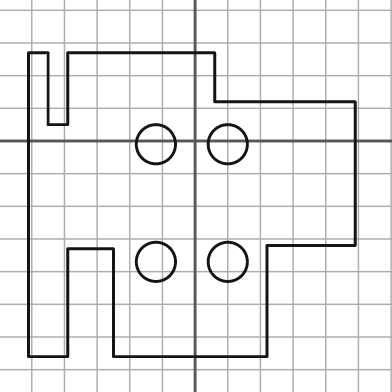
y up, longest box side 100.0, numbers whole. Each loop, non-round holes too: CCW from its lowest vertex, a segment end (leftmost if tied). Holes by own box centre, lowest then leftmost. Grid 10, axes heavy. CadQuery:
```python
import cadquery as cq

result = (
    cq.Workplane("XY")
    .moveTo(-51.0, -66.0)
    .lineTo(-39.0, -66.0)
    .lineTo(-39.0, -33.0)
    .lineTo(-25.0, -33.0)
    .lineTo(-25.0, -66.0)
    .lineTo(22.0, -66.0)
    .lineTo(22.0, -32.0)
    .lineTo(49.0, -32.0)
    .lineTo(49.0, 12.0)
    .lineTo(6.0, 12.0)
    .lineTo(6.0, 27.0)
    .lineTo(-39.0, 27.0)
    .lineTo(-39.0, 5.0)
    .lineTo(-45.0, 5.0)
    .lineTo(-45.0, 27.0)
    .lineTo(-51.0, 27.0)
    .close()
    .moveTo(-12.0, -37.0)
    .circle(6.0)
    .moveTo(10.0, -37.0)
    .circle(6.0)
    .moveTo(-12.0, -1.0)
    .circle(6.0)
    .moveTo(10.0, -1.0)
    .circle(6.0)
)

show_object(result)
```